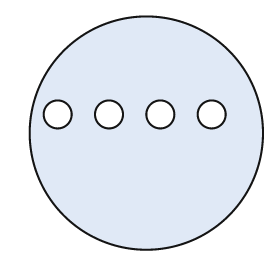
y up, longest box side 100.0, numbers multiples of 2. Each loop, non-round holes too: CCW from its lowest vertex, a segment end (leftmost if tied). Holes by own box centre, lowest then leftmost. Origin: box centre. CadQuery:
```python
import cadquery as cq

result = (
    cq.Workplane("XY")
    .moveTo(0.0, 0.0)
    .circle(50.0)
    .moveTo(-38.0, 8.0)
    .circle(6.0)
    .moveTo(-16.0, 8.0)
    .circle(6.0)
    .moveTo(6.0, 8.0)
    .circle(6.0)
    .moveTo(28.0, 8.0)
    .circle(6.0)
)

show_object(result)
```